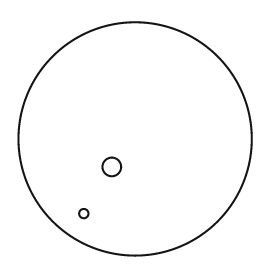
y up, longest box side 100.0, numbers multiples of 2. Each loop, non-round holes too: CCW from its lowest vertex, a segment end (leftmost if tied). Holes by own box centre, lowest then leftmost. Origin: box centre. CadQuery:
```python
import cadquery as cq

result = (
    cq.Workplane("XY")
    .moveTo(0.0, 0.0)
    .circle(50.0)
    .moveTo(-22.0, -32.0)
    .circle(2.0)
    .moveTo(-10.0, -12.0)
    .circle(4.0)
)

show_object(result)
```